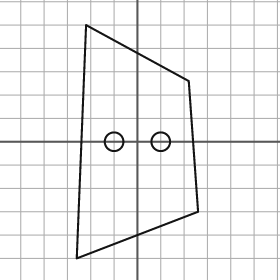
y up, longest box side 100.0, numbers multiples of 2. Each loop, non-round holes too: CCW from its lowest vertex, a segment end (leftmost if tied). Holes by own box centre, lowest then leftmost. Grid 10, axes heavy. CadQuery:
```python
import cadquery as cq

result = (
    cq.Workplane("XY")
    .moveTo(-26.0, -50.0)
    .lineTo(26.0, -30.0)
    .lineTo(22.0, 26.0)
    .lineTo(-22.0, 50.0)
    .close()
    .moveTo(-10.0, 0.0)
    .circle(4.0)
    .moveTo(10.0, 0.0)
    .circle(4.0)
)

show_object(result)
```